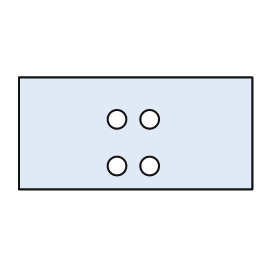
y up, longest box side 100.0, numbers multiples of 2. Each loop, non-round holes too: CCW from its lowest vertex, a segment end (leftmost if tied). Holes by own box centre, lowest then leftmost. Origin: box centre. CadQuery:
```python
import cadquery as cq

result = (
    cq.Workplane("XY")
    .moveTo(-50.0, -24.0)
    .lineTo(50.0, -24.0)
    .lineTo(50.0, 24.0)
    .lineTo(-50.0, 24.0)
    .close()
    .moveTo(-8.0, -14.0)
    .circle(4.0)
    .moveTo(6.0, -14.0)
    .circle(4.0)
    .moveTo(-8.0, 6.0)
    .circle(4.0)
    .moveTo(6.0, 6.0)
    .circle(4.0)
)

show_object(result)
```